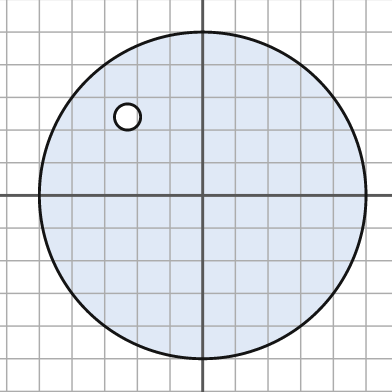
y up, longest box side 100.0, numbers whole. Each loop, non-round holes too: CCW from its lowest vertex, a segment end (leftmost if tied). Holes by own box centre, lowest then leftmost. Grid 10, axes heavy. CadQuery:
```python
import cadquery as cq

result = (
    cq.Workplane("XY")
    .moveTo(0.0, 0.0)
    .circle(50.0)
    .moveTo(-23.0, 24.0)
    .circle(4.0)
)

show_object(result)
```